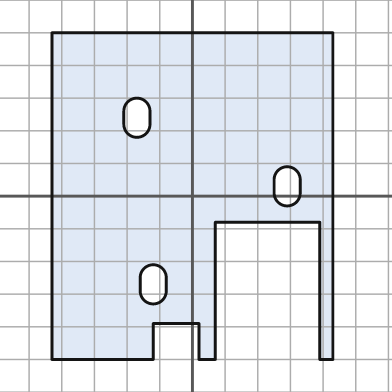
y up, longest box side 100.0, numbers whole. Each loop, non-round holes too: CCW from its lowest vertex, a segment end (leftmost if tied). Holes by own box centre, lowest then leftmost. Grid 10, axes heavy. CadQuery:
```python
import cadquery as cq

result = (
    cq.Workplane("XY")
    .moveTo(-43.0, -50.0)
    .lineTo(-12.0, -50.0)
    .lineTo(-12.0, -39.0)
    .lineTo(2.0, -39.0)
    .lineTo(2.0, -50.0)
    .lineTo(7.0, -50.0)
    .lineTo(7.0, -8.0)
    .lineTo(39.0, -8.0)
    .lineTo(39.0, -50.0)
    .lineTo(43.0, -50.0)
    .lineTo(43.0, 50.0)
    .lineTo(-43.0, 50.0)
    .close()
    .moveTo(-16.0, -29.0)
    .threePointArc((-12.0, -33.0), (-8.0, -29.0))
    .lineTo(-8.0, -25.0)
    .threePointArc((-12.0, -21.0), (-16.0, -25.0))
    .close()
    .moveTo(25.0, 1.0)
    .threePointArc((29.0, -3.0), (33.0, 1.0))
    .lineTo(33.0, 5.0)
    .threePointArc((29.0, 9.0), (25.0, 5.0))
    .close()
    .moveTo(-21.0, 22.0)
    .threePointArc((-17.0, 18.0), (-13.0, 22.0))
    .lineTo(-13.0, 26.0)
    .threePointArc((-17.0, 30.0), (-21.0, 26.0))
    .close()
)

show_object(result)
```